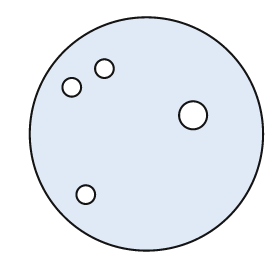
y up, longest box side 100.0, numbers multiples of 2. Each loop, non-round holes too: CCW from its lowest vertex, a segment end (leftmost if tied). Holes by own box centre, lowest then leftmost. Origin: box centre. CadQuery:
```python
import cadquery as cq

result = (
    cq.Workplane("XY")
    .moveTo(0.0, 0.0)
    .circle(50.0)
    .moveTo(-26.0, -26.0)
    .circle(4.0)
    .moveTo(20.0, 8.0)
    .circle(6.0)
    .moveTo(-32.0, 20.0)
    .circle(4.0)
    .moveTo(-18.0, 28.0)
    .circle(4.0)
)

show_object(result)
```